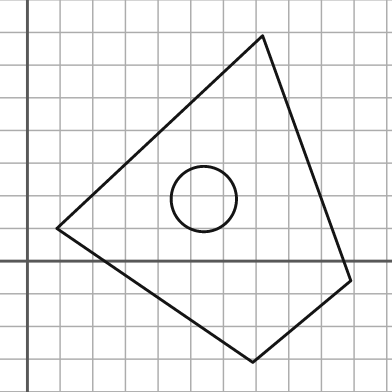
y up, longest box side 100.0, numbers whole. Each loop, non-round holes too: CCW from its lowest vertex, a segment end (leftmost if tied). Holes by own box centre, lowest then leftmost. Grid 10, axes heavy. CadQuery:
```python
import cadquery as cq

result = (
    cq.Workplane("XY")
    .moveTo(69.0, -31.0)
    .lineTo(99.0, -6.0)
    .lineTo(72.0, 69.0)
    .lineTo(9.0, 10.0)
    .close()
    .moveTo(54.0, 19.0)
    .circle(10.0)
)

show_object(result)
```